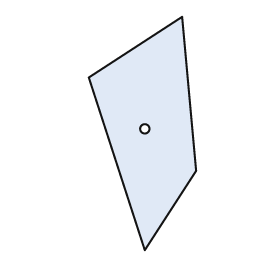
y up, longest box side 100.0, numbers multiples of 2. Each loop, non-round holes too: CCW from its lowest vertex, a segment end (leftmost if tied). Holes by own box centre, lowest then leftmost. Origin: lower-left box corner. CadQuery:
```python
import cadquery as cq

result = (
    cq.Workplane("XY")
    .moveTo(24.0, 0.0)
    .lineTo(46.0, 34.0)
    .lineTo(40.0, 100.0)
    .lineTo(0.0, 74.0)
    .close()
    .moveTo(24.0, 52.0)
    .circle(2.0)
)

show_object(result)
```